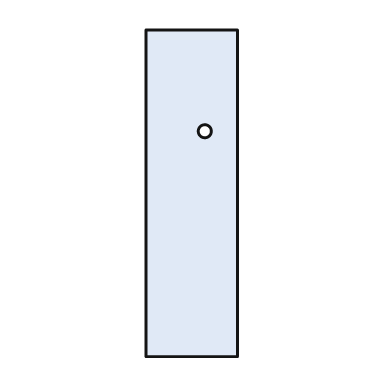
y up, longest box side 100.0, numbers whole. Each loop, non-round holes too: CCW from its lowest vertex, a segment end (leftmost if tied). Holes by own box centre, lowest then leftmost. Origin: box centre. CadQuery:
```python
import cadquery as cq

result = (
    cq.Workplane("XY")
    .moveTo(-14.0, -50.0)
    .lineTo(14.0, -50.0)
    .lineTo(14.0, 50.0)
    .lineTo(-14.0, 50.0)
    .close()
    .moveTo(4.0, 19.0)
    .circle(2.0)
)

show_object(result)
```